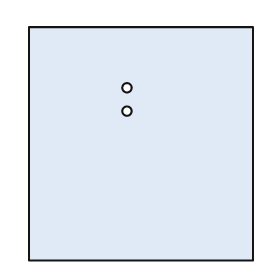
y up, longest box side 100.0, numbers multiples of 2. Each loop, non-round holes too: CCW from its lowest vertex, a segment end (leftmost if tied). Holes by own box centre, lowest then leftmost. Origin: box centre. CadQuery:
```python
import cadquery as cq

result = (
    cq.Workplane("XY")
    .moveTo(-48.0, -50.0)
    .lineTo(48.0, -50.0)
    .lineTo(48.0, 50.0)
    .lineTo(-48.0, 50.0)
    .close()
    .moveTo(-6.0, 14.0)
    .circle(2.0)
    .moveTo(-6.0, 24.0)
    .circle(2.0)
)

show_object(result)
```